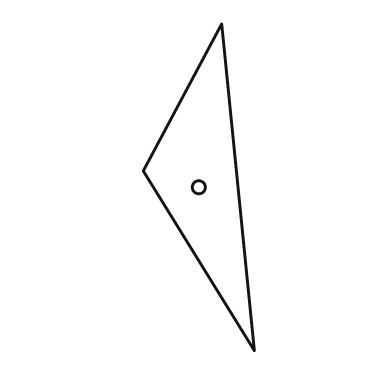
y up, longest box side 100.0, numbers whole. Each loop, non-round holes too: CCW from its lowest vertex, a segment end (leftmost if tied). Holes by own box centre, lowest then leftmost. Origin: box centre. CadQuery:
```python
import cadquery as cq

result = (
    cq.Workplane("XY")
    .moveTo(17.0, -50.0)
    .lineTo(7.0, 50.0)
    .lineTo(-17.0, 5.0)
    .close()
    .moveTo(0.0, 0.0)
    .circle(2.0)
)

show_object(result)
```